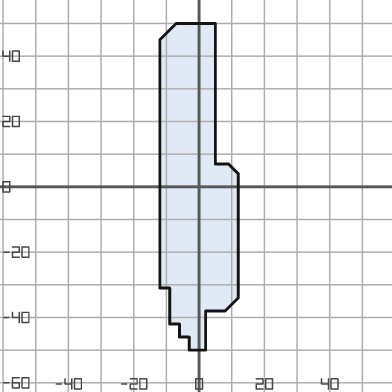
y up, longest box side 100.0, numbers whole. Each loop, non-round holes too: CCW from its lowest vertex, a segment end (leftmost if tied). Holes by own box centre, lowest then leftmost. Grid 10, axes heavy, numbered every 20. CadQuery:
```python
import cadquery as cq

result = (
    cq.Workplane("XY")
    .moveTo(-3.0, -50.0)
    .lineTo(2.0, -50.0)
    .lineTo(2.0, -38.0)
    .lineTo(8.0, -38.0)
    .lineTo(12.0, -34.0)
    .lineTo(12.0, 4.0)
    .lineTo(9.0, 7.0)
    .lineTo(5.0, 7.0)
    .lineTo(5.0, 50.0)
    .lineTo(-7.0, 50.0)
    .lineTo(-12.0, 45.0)
    .lineTo(-12.0, -31.0)
    .lineTo(-9.0, -31.0)
    .lineTo(-9.0, -42.0)
    .lineTo(-6.0, -42.0)
    .lineTo(-6.0, -46.0)
    .lineTo(-3.0, -46.0)
    .close()
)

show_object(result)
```